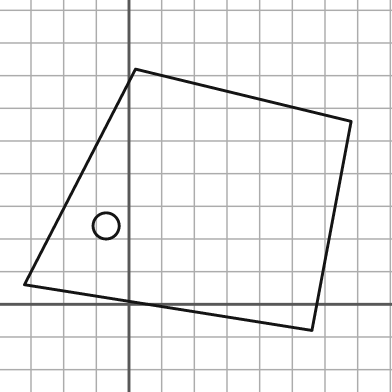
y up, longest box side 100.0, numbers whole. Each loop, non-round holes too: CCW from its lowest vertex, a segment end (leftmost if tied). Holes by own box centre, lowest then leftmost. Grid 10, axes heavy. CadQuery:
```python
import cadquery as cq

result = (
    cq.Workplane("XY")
    .moveTo(56.0, -8.0)
    .lineTo(68.0, 56.0)
    .lineTo(2.0, 72.0)
    .lineTo(-32.0, 6.0)
    .close()
    .moveTo(-7.0, 24.0)
    .circle(4.0)
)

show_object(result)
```